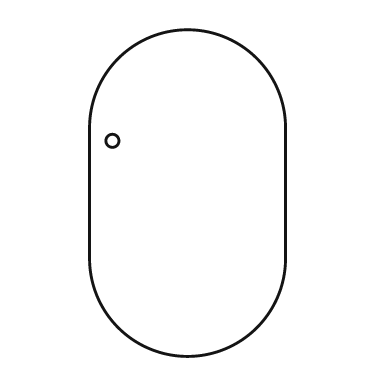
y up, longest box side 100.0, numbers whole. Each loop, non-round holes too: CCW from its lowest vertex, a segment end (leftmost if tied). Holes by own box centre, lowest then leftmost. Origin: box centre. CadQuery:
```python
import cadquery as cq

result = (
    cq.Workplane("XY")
    .moveTo(-30.0, -20.0)
    .threePointArc((0.0, -50.0), (30.0, -20.0))
    .lineTo(30.0, 20.0)
    .threePointArc((0.0, 50.0), (-30.0, 20.0))
    .close()
    .moveTo(-23.0, 16.0)
    .circle(2.0)
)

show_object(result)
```